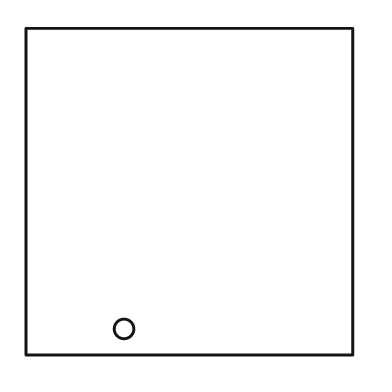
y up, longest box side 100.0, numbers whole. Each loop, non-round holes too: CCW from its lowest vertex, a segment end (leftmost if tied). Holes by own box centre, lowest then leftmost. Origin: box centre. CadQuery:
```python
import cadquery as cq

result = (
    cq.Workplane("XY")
    .moveTo(-50.0, -50.0)
    .lineTo(50.0, -50.0)
    .lineTo(50.0, 50.0)
    .lineTo(-50.0, 50.0)
    .close()
    .moveTo(-20.0, -42.0)
    .circle(3.0)
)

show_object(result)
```